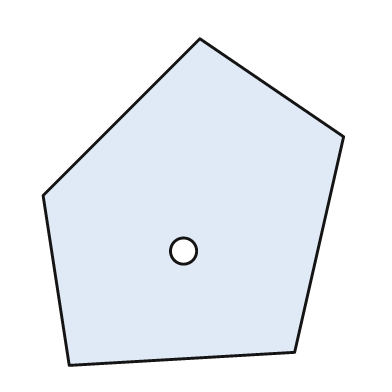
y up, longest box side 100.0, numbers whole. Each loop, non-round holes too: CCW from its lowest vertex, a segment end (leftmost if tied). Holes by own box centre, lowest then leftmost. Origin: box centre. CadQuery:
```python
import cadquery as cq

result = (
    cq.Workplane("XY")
    .moveTo(-38.0, -50.0)
    .lineTo(31.0, -46.0)
    .lineTo(46.0, 20.0)
    .lineTo(2.0, 50.0)
    .lineTo(-46.0, 2.0)
    .close()
    .moveTo(-3.0, -15.0)
    .circle(4.0)
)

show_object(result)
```